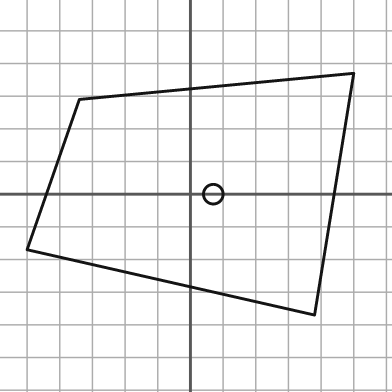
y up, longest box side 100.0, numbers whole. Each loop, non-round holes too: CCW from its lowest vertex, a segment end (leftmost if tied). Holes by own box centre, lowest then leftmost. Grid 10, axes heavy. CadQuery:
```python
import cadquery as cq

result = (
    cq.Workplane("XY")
    .moveTo(38.0, -37.0)
    .lineTo(50.0, 37.0)
    .lineTo(-34.0, 29.0)
    .lineTo(-50.0, -17.0)
    .close()
    .moveTo(7.0, 0.0)
    .circle(3.0)
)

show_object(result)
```